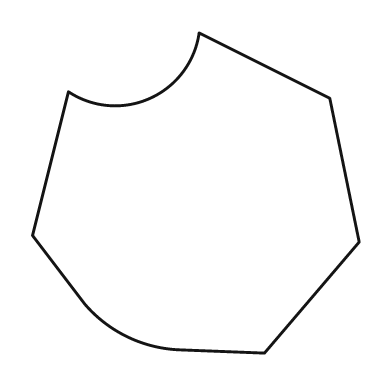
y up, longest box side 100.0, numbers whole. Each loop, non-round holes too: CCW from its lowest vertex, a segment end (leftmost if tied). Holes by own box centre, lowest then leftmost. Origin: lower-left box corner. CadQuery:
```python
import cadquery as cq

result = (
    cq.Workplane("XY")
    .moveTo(71.0, 0.0)
    .lineTo(100.0, 34.0)
    .lineTo(91.0, 78.0)
    .lineTo(51.0, 98.0)
    .threePointArc((36.0, 78.0), (11.0, 80.0))
    .lineTo(0.0, 36.0)
    .lineTo(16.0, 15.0)
    .threePointArc((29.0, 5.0), (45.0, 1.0))
    .close()
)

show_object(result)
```